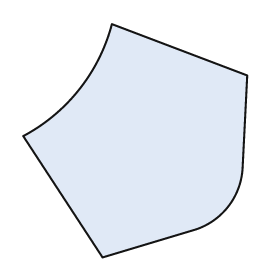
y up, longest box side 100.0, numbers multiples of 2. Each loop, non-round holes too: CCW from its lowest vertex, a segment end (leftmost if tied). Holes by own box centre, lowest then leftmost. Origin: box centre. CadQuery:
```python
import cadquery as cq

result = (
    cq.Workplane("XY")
    .moveTo(-14.0, -50.0)
    .lineTo(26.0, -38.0)
    .threePointArc((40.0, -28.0), (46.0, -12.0))
    .lineTo(48.0, 28.0)
    .lineTo(-10.0, 50.0)
    .threePointArc((-24.0, 22.0), (-48.0, 2.0))
    .close()
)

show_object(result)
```